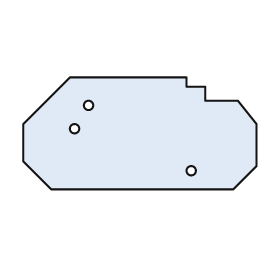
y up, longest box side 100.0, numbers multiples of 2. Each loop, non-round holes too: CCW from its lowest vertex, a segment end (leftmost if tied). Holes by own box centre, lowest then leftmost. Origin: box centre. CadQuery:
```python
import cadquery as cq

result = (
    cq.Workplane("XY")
    .moveTo(-38.0, -24.0)
    .lineTo(40.0, -24.0)
    .lineTo(50.0, -14.0)
    .lineTo(50.0, 4.0)
    .lineTo(42.0, 14.0)
    .lineTo(28.0, 14.0)
    .lineTo(28.0, 20.0)
    .lineTo(20.0, 20.0)
    .lineTo(20.0, 24.0)
    .lineTo(-30.0, 24.0)
    .lineTo(-50.0, 4.0)
    .lineTo(-50.0, -12.0)
    .close()
    .moveTo(22.0, -16.0)
    .circle(2.0)
    .moveTo(-28.0, 2.0)
    .circle(2.0)
    .moveTo(-22.0, 12.0)
    .circle(2.0)
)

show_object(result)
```